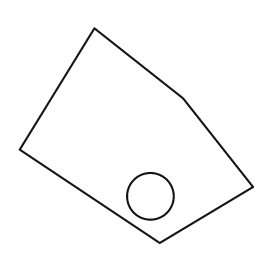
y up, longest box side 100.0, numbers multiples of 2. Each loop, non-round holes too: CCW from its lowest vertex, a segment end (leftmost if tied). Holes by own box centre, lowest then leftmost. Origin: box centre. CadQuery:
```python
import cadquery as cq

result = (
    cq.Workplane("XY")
    .moveTo(10.0, -46.0)
    .lineTo(50.0, -22.0)
    .lineTo(20.0, 16.0)
    .lineTo(-18.0, 46.0)
    .lineTo(-50.0, -6.0)
    .close()
    .moveTo(6.0, -26.0)
    .circle(10.0)
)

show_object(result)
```